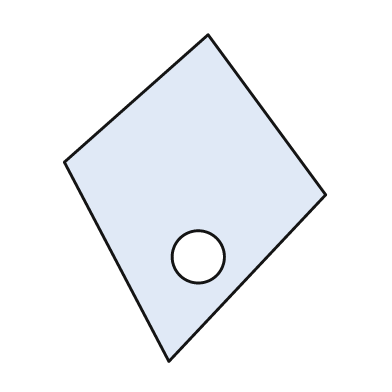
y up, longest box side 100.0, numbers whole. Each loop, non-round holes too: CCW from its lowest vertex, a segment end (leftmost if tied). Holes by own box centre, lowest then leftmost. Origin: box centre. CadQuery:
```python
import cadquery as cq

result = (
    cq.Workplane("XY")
    .moveTo(-8.0, -50.0)
    .lineTo(40.0, 1.0)
    .lineTo(4.0, 50.0)
    .lineTo(-40.0, 11.0)
    .close()
    .moveTo(1.0, -18.0)
    .circle(8.0)
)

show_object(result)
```